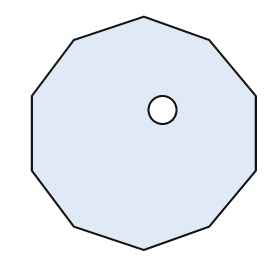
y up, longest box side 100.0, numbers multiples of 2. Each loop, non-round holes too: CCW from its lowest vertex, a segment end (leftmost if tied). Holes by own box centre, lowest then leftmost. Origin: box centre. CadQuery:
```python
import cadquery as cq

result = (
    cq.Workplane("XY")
    .moveTo(0.0, -50.0)
    .lineTo(28.0, -40.0)
    .lineTo(48.0, -16.0)
    .lineTo(48.0, 16.0)
    .lineTo(28.0, 40.0)
    .lineTo(0.0, 50.0)
    .lineTo(-30.0, 40.0)
    .lineTo(-48.0, 16.0)
    .lineTo(-48.0, -16.0)
    .lineTo(-30.0, -40.0)
    .close()
    .moveTo(8.0, 10.0)
    .circle(6.0)
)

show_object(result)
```